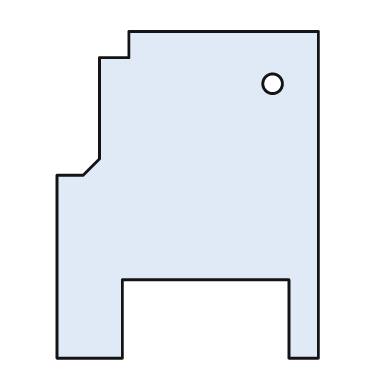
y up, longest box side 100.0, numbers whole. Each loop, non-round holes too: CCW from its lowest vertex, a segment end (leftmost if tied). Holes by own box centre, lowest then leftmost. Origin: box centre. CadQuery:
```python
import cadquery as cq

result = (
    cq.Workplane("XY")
    .moveTo(-40.0, -50.0)
    .lineTo(-20.0, -50.0)
    .lineTo(-20.0, -26.0)
    .lineTo(31.0, -26.0)
    .lineTo(31.0, -50.0)
    .lineTo(40.0, -50.0)
    .lineTo(40.0, 50.0)
    .lineTo(-18.0, 50.0)
    .lineTo(-18.0, 42.0)
    .lineTo(-27.0, 42.0)
    .lineTo(-27.0, 11.0)
    .lineTo(-32.0, 6.0)
    .lineTo(-40.0, 6.0)
    .close()
    .moveTo(26.0, 34.0)
    .circle(3.0)
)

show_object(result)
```